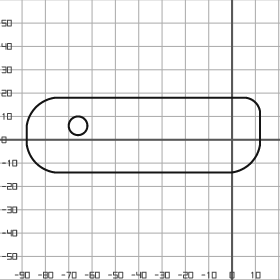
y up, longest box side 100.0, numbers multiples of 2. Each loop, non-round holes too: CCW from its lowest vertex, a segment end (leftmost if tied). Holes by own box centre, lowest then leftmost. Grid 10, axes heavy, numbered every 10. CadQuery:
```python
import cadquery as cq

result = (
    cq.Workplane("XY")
    .moveTo(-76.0, -14.0)
    .lineTo(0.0, -14.0)
    .threePointArc((8.0, -10.0), (12.0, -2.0))
    .lineTo(12.0, 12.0)
    .threePointArc((10.0, 16.0), (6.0, 18.0))
    .lineTo(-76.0, 18.0)
    .threePointArc((-84.0, 14.0), (-88.0, 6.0))
    .lineTo(-88.0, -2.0)
    .threePointArc((-84.0, -10.0), (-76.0, -14.0))
    .close()
    .moveTo(-66.0, 6.0)
    .circle(4.0)
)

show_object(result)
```